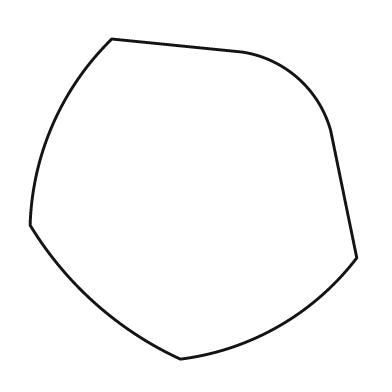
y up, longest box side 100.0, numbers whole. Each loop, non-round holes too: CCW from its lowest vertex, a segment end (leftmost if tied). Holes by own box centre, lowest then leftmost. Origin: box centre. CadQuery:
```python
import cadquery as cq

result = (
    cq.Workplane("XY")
    .moveTo(-4.0, -49.0)
    .threePointArc((26.0, -39.0), (50.0, -18.0))
    .lineTo(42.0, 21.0)
    .threePointArc((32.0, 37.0), (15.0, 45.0))
    .lineTo(-25.0, 49.0)
    .threePointArc((-43.0, 23.0), (-50.0, -8.0))
    .threePointArc((-30.0, -32.0), (-4.0, -49.0))
    .close()
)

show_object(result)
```